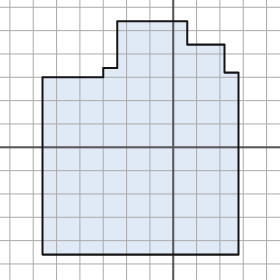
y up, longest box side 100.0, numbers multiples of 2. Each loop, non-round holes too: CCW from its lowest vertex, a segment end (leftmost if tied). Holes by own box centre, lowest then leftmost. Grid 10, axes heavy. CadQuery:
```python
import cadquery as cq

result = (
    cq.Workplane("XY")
    .moveTo(-56.0, -46.0)
    .lineTo(28.0, -46.0)
    .lineTo(28.0, 32.0)
    .lineTo(22.0, 32.0)
    .lineTo(22.0, 44.0)
    .lineTo(6.0, 44.0)
    .lineTo(6.0, 54.0)
    .lineTo(-24.0, 54.0)
    .lineTo(-24.0, 34.0)
    .lineTo(-30.0, 34.0)
    .lineTo(-30.0, 30.0)
    .lineTo(-56.0, 30.0)
    .close()
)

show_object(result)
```